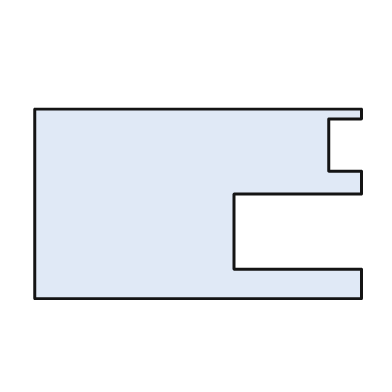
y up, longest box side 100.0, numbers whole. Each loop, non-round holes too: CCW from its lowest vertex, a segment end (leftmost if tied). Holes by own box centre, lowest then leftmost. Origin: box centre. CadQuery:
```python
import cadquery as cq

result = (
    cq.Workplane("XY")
    .moveTo(-50.0, -29.0)
    .lineTo(50.0, -29.0)
    .lineTo(50.0, -20.0)
    .lineTo(11.0, -20.0)
    .lineTo(11.0, 3.0)
    .lineTo(50.0, 3.0)
    .lineTo(50.0, 10.0)
    .lineTo(40.0, 10.0)
    .lineTo(40.0, 26.0)
    .lineTo(50.0, 26.0)
    .lineTo(50.0, 29.0)
    .lineTo(-50.0, 29.0)
    .close()
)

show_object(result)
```